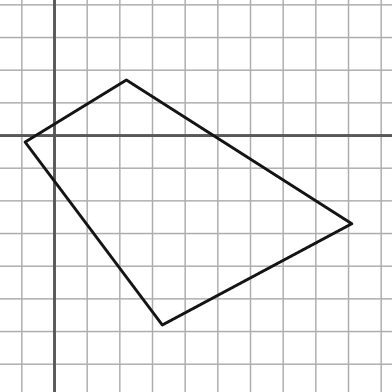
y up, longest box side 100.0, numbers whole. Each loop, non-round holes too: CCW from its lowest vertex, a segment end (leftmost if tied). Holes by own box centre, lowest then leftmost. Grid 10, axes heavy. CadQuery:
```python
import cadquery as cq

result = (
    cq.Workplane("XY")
    .moveTo(33.0, -58.0)
    .lineTo(91.0, -27.0)
    .lineTo(22.0, 17.0)
    .lineTo(-9.0, -2.0)
    .close()
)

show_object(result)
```